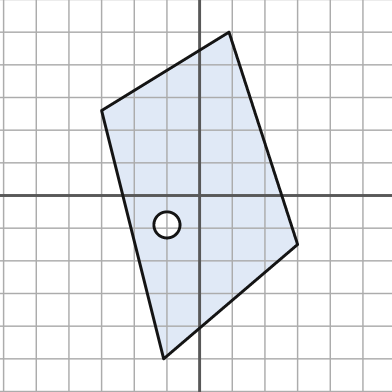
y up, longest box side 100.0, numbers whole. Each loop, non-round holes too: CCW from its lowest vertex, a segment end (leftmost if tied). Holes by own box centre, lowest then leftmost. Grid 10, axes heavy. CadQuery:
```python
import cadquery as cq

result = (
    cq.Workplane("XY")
    .moveTo(-11.0, -50.0)
    .lineTo(30.0, -15.0)
    .lineTo(9.0, 50.0)
    .lineTo(-30.0, 26.0)
    .close()
    .moveTo(-10.0, -9.0)
    .circle(4.0)
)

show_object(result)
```